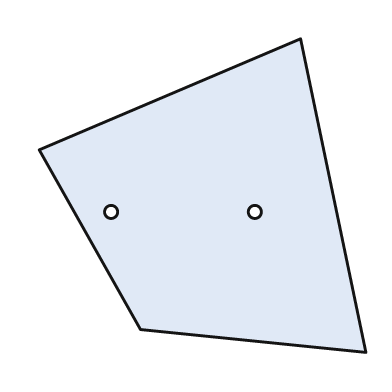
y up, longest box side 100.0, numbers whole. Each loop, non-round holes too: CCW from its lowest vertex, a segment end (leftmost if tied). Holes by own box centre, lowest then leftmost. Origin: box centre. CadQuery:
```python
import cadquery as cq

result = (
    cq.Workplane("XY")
    .moveTo(50.0, -48.0)
    .lineTo(30.0, 48.0)
    .lineTo(-50.0, 14.0)
    .lineTo(-19.0, -41.0)
    .close()
    .moveTo(-28.0, -5.0)
    .circle(2.0)
    .moveTo(16.0, -5.0)
    .circle(2.0)
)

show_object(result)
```